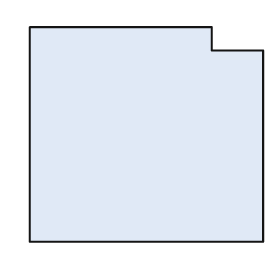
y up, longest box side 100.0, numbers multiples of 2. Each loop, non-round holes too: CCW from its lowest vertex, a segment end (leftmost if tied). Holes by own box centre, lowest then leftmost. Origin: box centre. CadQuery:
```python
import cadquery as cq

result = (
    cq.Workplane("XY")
    .moveTo(-50.0, -46.0)
    .lineTo(50.0, -46.0)
    .lineTo(50.0, 36.0)
    .lineTo(28.0, 36.0)
    .lineTo(28.0, 46.0)
    .lineTo(-50.0, 46.0)
    .close()
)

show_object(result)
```